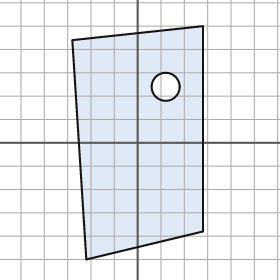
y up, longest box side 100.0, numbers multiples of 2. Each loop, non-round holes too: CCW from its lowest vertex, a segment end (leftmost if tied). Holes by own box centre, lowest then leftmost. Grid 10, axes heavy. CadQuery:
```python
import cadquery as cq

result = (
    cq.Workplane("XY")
    .moveTo(-22.0, -50.0)
    .lineTo(28.0, -38.0)
    .lineTo(28.0, 50.0)
    .lineTo(-28.0, 44.0)
    .close()
    .moveTo(12.0, 24.0)
    .circle(6.0)
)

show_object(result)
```